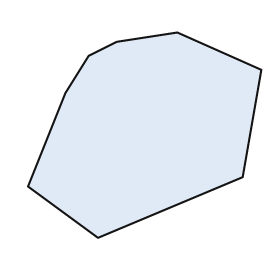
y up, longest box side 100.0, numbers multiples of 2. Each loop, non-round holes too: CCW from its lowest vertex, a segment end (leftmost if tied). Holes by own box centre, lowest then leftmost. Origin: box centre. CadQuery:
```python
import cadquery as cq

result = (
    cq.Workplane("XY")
    .moveTo(-20.0, -44.0)
    .lineTo(42.0, -18.0)
    .lineTo(50.0, 28.0)
    .lineTo(14.0, 44.0)
    .lineTo(-12.0, 40.0)
    .lineTo(-24.0, 34.0)
    .lineTo(-34.0, 18.0)
    .lineTo(-50.0, -22.0)
    .close()
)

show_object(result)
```